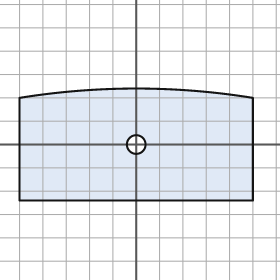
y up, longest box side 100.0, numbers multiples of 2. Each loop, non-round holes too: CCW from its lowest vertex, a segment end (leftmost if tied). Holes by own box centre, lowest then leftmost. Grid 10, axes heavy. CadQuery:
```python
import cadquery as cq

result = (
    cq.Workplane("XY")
    .moveTo(-50.0, -24.0)
    .lineTo(50.0, -24.0)
    .lineTo(50.0, 20.0)
    .threePointArc((0.0, 24.0), (-50.0, 20.0))
    .close()
    .moveTo(0.0, 0.0)
    .circle(4.0)
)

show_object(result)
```